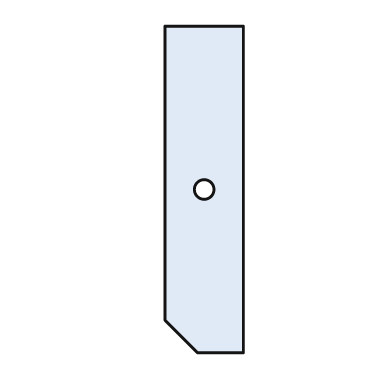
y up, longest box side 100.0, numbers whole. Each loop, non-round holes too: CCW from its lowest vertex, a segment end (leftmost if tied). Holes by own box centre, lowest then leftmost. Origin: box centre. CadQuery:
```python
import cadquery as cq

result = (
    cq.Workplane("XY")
    .moveTo(-2.0, -50.0)
    .lineTo(12.0, -50.0)
    .lineTo(12.0, 50.0)
    .lineTo(-12.0, 50.0)
    .lineTo(-12.0, -40.0)
    .close()
    .moveTo(0.0, 0.0)
    .circle(3.0)
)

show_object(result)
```